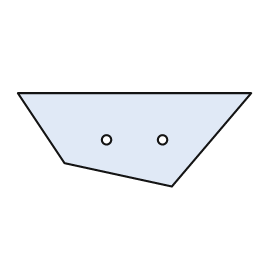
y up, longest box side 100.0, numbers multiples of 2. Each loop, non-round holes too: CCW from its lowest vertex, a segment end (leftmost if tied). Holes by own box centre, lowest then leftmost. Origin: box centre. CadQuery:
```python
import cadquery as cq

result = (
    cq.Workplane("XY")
    .moveTo(16.0, -20.0)
    .lineTo(50.0, 20.0)
    .lineTo(-50.0, 20.0)
    .lineTo(-30.0, -10.0)
    .close()
    .moveTo(-12.0, 0.0)
    .circle(2.0)
    .moveTo(12.0, 0.0)
    .circle(2.0)
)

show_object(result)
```